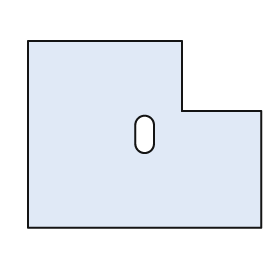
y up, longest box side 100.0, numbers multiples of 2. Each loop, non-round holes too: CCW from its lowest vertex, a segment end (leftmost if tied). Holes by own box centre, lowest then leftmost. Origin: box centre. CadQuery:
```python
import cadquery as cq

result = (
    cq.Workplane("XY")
    .moveTo(-50.0, -40.0)
    .lineTo(50.0, -40.0)
    .lineTo(50.0, 10.0)
    .lineTo(16.0, 10.0)
    .lineTo(16.0, 40.0)
    .lineTo(-50.0, 40.0)
    .close()
    .moveTo(-4.0, -4.0)
    .threePointArc((0.0, -8.0), (4.0, -4.0))
    .lineTo(4.0, 4.0)
    .threePointArc((0.0, 8.0), (-4.0, 4.0))
    .close()
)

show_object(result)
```